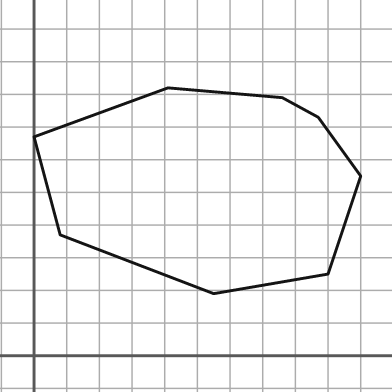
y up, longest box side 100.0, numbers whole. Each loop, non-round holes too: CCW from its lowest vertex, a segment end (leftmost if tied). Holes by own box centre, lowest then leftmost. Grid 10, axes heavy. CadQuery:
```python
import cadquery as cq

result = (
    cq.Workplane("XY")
    .moveTo(55.0, 19.0)
    .lineTo(90.0, 25.0)
    .lineTo(100.0, 55.0)
    .lineTo(87.0, 73.0)
    .lineTo(76.0, 79.0)
    .lineTo(41.0, 82.0)
    .lineTo(0.0, 67.0)
    .lineTo(8.0, 37.0)
    .close()
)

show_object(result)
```